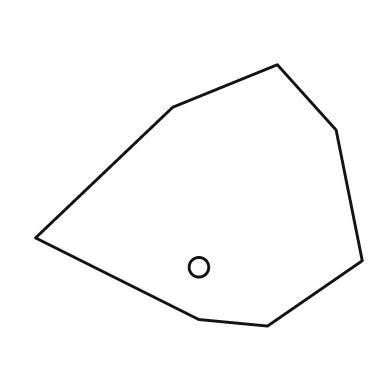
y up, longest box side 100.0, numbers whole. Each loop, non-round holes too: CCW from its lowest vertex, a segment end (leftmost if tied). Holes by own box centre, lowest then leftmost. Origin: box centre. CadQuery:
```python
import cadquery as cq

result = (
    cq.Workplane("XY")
    .moveTo(21.0, -40.0)
    .lineTo(50.0, -20.0)
    .lineTo(42.0, 20.0)
    .lineTo(24.0, 40.0)
    .lineTo(-8.0, 27.0)
    .lineTo(-50.0, -13.0)
    .lineTo(0.0, -38.0)
    .close()
    .moveTo(0.0, -22.0)
    .circle(3.0)
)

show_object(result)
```